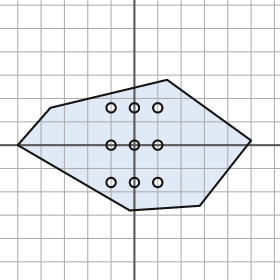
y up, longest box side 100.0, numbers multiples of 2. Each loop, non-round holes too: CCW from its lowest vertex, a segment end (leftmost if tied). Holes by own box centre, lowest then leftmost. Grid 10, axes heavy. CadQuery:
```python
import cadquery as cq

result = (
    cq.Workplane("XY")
    .moveTo(-2.0, -28.0)
    .lineTo(28.0, -26.0)
    .lineTo(50.0, 2.0)
    .lineTo(14.0, 28.0)
    .lineTo(-36.0, 16.0)
    .lineTo(-50.0, 0.0)
    .close()
    .moveTo(-10.0, -16.0)
    .circle(2.0)
    .moveTo(0.0, -16.0)
    .circle(2.0)
    .moveTo(10.0, -16.0)
    .circle(2.0)
    .moveTo(-10.0, 0.0)
    .circle(2.0)
    .moveTo(0.0, 0.0)
    .circle(2.0)
    .moveTo(10.0, 0.0)
    .circle(2.0)
    .moveTo(-10.0, 16.0)
    .circle(2.0)
    .moveTo(0.0, 16.0)
    .circle(2.0)
    .moveTo(10.0, 16.0)
    .circle(2.0)
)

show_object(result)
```